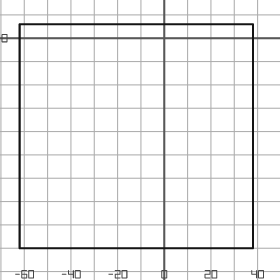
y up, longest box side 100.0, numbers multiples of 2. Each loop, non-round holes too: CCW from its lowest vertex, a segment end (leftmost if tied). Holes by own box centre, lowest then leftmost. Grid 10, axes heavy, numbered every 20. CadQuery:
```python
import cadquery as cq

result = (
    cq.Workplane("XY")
    .moveTo(-62.0, -90.0)
    .lineTo(38.0, -90.0)
    .lineTo(38.0, 6.0)
    .lineTo(-62.0, 6.0)
    .close()
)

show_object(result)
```